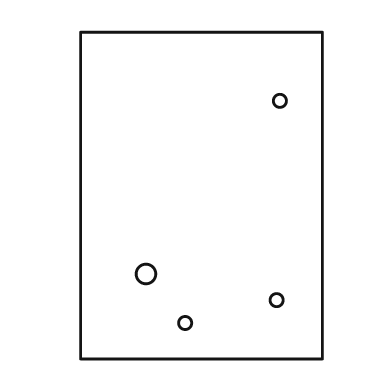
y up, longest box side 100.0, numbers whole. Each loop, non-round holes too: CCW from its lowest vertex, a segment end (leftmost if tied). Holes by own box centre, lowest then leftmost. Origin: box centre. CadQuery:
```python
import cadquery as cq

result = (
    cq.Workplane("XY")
    .moveTo(-37.0, -50.0)
    .lineTo(37.0, -50.0)
    .lineTo(37.0, 50.0)
    .lineTo(-37.0, 50.0)
    .close()
    .moveTo(-5.0, -39.0)
    .circle(2.0)
    .moveTo(23.0, -32.0)
    .circle(2.0)
    .moveTo(-17.0, -24.0)
    .circle(3.0)
    .moveTo(24.0, 29.0)
    .circle(2.0)
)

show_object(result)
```